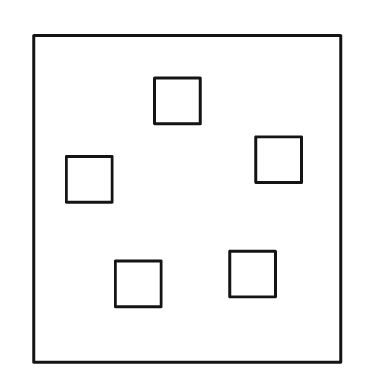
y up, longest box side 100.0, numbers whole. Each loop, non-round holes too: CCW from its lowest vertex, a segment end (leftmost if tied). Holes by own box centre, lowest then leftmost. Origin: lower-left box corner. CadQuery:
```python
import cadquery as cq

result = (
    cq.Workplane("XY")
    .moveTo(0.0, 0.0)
    .lineTo(94.0, 0.0)
    .lineTo(94.0, 100.0)
    .lineTo(0.0, 100.0)
    .close()
    .moveTo(25.0, 17.0)
    .lineTo(39.0, 17.0)
    .lineTo(39.0, 31.0)
    .lineTo(25.0, 31.0)
    .close()
    .moveTo(60.0, 20.0)
    .lineTo(74.0, 20.0)
    .lineTo(74.0, 34.0)
    .lineTo(60.0, 34.0)
    .close()
    .moveTo(10.0, 49.0)
    .lineTo(24.0, 49.0)
    .lineTo(24.0, 63.0)
    .lineTo(10.0, 63.0)
    .close()
    .moveTo(68.0, 55.0)
    .lineTo(82.0, 55.0)
    .lineTo(82.0, 69.0)
    .lineTo(68.0, 69.0)
    .close()
    .moveTo(37.0, 73.0)
    .lineTo(51.0, 73.0)
    .lineTo(51.0, 87.0)
    .lineTo(37.0, 87.0)
    .close()
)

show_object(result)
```